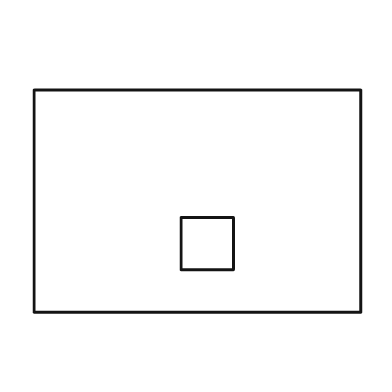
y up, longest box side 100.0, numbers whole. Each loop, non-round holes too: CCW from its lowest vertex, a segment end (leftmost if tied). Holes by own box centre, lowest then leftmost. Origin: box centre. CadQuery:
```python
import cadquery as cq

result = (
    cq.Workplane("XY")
    .moveTo(-50.0, -34.0)
    .lineTo(50.0, -34.0)
    .lineTo(50.0, 34.0)
    .lineTo(-50.0, 34.0)
    .close()
    .moveTo(-5.0, -21.0)
    .lineTo(11.0, -21.0)
    .lineTo(11.0, -5.0)
    .lineTo(-5.0, -5.0)
    .close()
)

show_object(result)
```